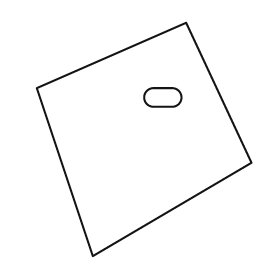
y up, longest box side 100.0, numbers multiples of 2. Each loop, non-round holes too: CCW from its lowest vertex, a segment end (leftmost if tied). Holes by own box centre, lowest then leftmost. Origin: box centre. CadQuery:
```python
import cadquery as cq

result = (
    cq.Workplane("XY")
    .moveTo(-22.0, -50.0)
    .lineTo(46.0, -10.0)
    .lineTo(18.0, 50.0)
    .lineTo(-46.0, 22.0)
    .close()
    .moveTo(4.0, 14.0)
    .lineTo(12.0, 14.0)
    .threePointArc((16.0, 18.0), (12.0, 22.0))
    .lineTo(4.0, 22.0)
    .threePointArc((0.0, 18.0), (4.0, 14.0))
    .close()
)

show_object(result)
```